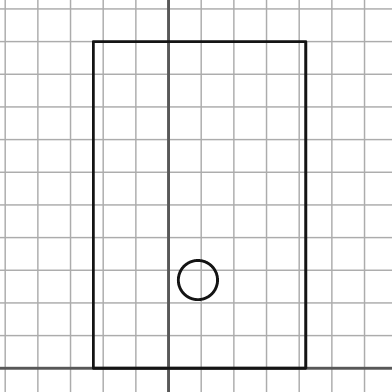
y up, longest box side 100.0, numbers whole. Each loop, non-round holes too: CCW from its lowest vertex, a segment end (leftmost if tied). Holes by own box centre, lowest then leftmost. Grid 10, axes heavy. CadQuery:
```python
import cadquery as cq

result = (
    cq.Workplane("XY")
    .moveTo(-23.0, 0.0)
    .lineTo(42.0, 0.0)
    .lineTo(42.0, 100.0)
    .lineTo(-23.0, 100.0)
    .close()
    .moveTo(9.0, 27.0)
    .circle(6.0)
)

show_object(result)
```